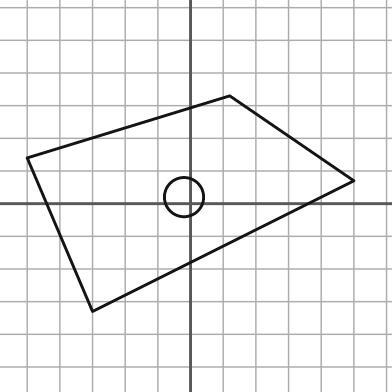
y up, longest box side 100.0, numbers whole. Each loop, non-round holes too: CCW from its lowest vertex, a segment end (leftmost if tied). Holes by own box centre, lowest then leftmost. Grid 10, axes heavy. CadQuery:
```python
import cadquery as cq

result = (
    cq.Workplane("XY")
    .moveTo(-30.0, -33.0)
    .lineTo(50.0, 7.0)
    .lineTo(12.0, 33.0)
    .lineTo(-50.0, 14.0)
    .close()
    .moveTo(-2.0, 2.0)
    .circle(6.0)
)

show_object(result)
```